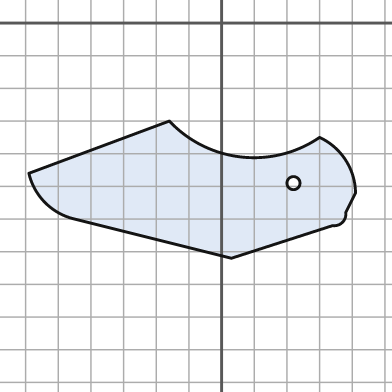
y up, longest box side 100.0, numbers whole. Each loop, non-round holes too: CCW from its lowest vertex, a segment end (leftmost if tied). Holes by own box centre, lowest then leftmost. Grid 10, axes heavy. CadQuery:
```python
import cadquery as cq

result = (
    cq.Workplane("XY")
    .moveTo(3.0, -72.0)
    .lineTo(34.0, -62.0)
    .threePointArc((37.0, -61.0), (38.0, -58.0))
    .lineTo(41.0, -52.0)
    .threePointArc((38.0, -42.0), (30.0, -35.0))
    .threePointArc((6.0, -41.0), (-16.0, -30.0))
    .lineTo(-59.0, -46.0)
    .threePointArc((-54.0, -55.0), (-45.0, -60.0))
    .close()
    .moveTo(22.0, -49.0)
    .circle(2.0)
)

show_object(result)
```